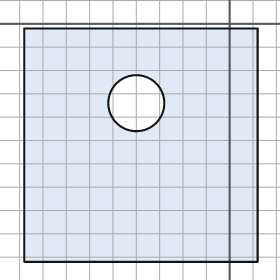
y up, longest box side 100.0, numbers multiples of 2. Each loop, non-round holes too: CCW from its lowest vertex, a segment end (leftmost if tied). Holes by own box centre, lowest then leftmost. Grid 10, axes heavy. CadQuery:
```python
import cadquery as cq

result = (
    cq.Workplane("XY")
    .moveTo(-88.0, -102.0)
    .lineTo(12.0, -102.0)
    .lineTo(12.0, -2.0)
    .lineTo(-88.0, -2.0)
    .close()
    .moveTo(-40.0, -34.0)
    .circle(12.0)
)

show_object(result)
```